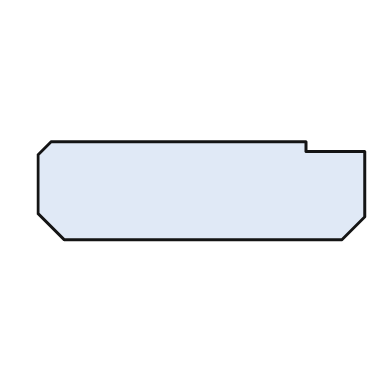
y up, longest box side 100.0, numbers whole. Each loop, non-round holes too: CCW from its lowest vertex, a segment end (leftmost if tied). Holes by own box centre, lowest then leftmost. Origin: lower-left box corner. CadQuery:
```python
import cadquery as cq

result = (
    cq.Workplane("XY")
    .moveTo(8.0, 0.0)
    .lineTo(93.0, 0.0)
    .lineTo(100.0, 7.0)
    .lineTo(100.0, 27.0)
    .lineTo(82.0, 27.0)
    .lineTo(82.0, 30.0)
    .lineTo(4.0, 30.0)
    .lineTo(0.0, 26.0)
    .lineTo(0.0, 8.0)
    .close()
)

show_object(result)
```